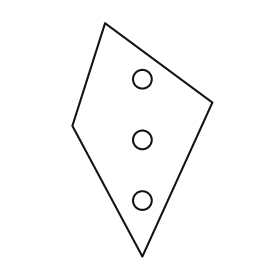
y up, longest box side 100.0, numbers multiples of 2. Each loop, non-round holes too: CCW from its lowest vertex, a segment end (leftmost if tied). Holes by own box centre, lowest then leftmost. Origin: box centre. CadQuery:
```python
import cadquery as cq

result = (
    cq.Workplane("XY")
    .moveTo(0.0, -50.0)
    .lineTo(30.0, 16.0)
    .lineTo(-16.0, 50.0)
    .lineTo(-30.0, 6.0)
    .close()
    .moveTo(0.0, -26.0)
    .circle(4.0)
    .moveTo(0.0, 0.0)
    .circle(4.0)
    .moveTo(0.0, 26.0)
    .circle(4.0)
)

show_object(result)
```